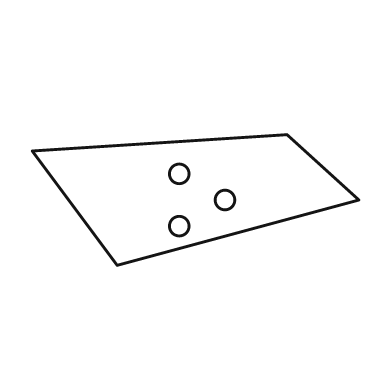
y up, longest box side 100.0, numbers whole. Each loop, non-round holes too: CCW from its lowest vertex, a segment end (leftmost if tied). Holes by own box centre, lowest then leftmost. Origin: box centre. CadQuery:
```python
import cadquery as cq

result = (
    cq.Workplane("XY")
    .moveTo(-24.0, -20.0)
    .lineTo(50.0, 0.0)
    .lineTo(28.0, 20.0)
    .lineTo(-50.0, 15.0)
    .close()
    .moveTo(-5.0, -8.0)
    .circle(3.0)
    .moveTo(9.0, 0.0)
    .circle(3.0)
    .moveTo(-5.0, 8.0)
    .circle(3.0)
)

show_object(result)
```